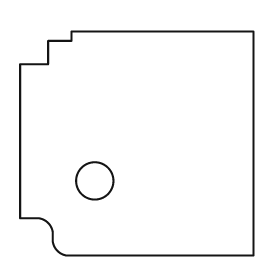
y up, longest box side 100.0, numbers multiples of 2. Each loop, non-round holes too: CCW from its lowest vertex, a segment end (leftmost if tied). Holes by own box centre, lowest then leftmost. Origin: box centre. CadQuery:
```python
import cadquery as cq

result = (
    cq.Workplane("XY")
    .moveTo(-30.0, -48.0)
    .lineTo(50.0, -48.0)
    .lineTo(50.0, 48.0)
    .lineTo(-28.0, 48.0)
    .lineTo(-28.0, 44.0)
    .lineTo(-38.0, 44.0)
    .lineTo(-38.0, 34.0)
    .lineTo(-50.0, 34.0)
    .lineTo(-50.0, -32.0)
    .lineTo(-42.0, -32.0)
    .threePointArc((-38.0, -34.0), (-36.0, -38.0))
    .lineTo(-36.0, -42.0)
    .threePointArc((-34.0, -46.0), (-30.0, -48.0))
    .close()
    .moveTo(-18.0, -16.0)
    .circle(8.0)
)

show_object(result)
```